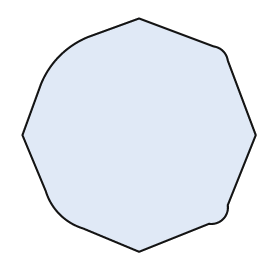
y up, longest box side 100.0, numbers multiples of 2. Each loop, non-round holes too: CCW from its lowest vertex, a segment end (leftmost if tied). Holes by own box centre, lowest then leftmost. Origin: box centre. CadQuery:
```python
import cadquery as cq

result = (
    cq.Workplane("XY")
    .moveTo(0.0, -50.0)
    .lineTo(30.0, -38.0)
    .threePointArc((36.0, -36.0), (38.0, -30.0))
    .lineTo(50.0, 0.0)
    .lineTo(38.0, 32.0)
    .threePointArc((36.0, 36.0), (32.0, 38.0))
    .lineTo(0.0, 50.0)
    .lineTo(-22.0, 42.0)
    .threePointArc((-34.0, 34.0), (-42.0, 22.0))
    .lineTo(-50.0, 0.0)
    .lineTo(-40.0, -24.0)
    .threePointArc((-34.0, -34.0), (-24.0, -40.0))
    .close()
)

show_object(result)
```